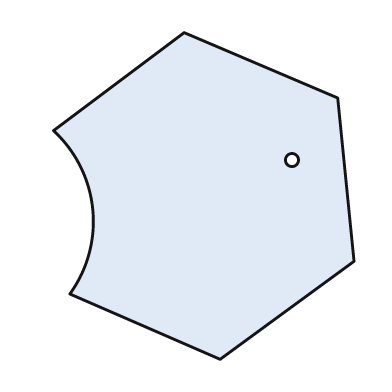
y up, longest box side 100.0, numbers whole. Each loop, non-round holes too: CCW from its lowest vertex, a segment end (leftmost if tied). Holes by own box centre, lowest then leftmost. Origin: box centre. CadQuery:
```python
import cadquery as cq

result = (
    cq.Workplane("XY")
    .moveTo(5.0, -50.0)
    .lineTo(46.0, -20.0)
    .lineTo(41.0, 30.0)
    .lineTo(-6.0, 50.0)
    .lineTo(-46.0, 20.0)
    .threePointArc((-34.0, -4.0), (-41.0, -30.0))
    .close()
    .moveTo(27.0, 11.0)
    .circle(2.0)
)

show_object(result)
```